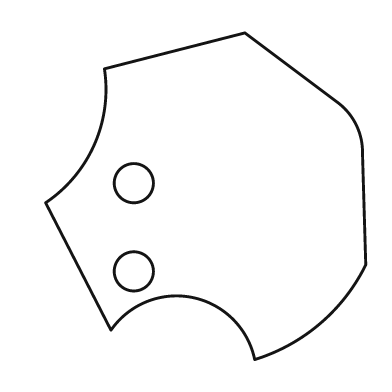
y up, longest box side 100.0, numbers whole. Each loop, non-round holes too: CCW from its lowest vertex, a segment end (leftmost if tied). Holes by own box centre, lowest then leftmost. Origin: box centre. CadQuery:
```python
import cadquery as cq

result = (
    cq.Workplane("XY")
    .moveTo(15.0, -50.0)
    .threePointArc((35.0, -39.0), (49.0, -21.0))
    .lineTo(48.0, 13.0)
    .threePointArc((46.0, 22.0), (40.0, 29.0))
    .lineTo(12.0, 50.0)
    .lineTo(-31.0, 39.0)
    .threePointArc((-34.0, 16.0), (-49.0, -2.0))
    .lineTo(-29.0, -41.0)
    .threePointArc((-4.0, -31.0), (15.0, -50.0))
    .close()
    .moveTo(-22.0, -23.0)
    .circle(6.0)
    .moveTo(-22.0, 4.0)
    .circle(6.0)
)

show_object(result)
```